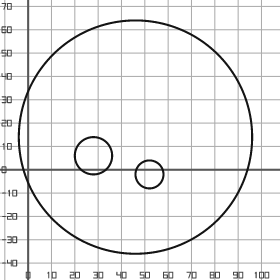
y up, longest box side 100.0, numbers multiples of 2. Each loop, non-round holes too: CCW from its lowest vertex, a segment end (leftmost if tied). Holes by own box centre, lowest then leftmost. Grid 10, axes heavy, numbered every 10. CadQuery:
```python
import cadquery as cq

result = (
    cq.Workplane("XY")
    .moveTo(46.0, 14.0)
    .circle(50.0)
    .moveTo(52.0, -2.0)
    .circle(6.0)
    .moveTo(28.0, 6.0)
    .circle(8.0)
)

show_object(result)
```